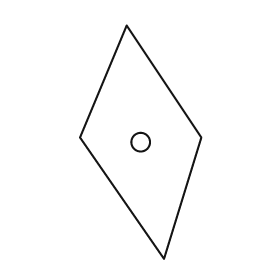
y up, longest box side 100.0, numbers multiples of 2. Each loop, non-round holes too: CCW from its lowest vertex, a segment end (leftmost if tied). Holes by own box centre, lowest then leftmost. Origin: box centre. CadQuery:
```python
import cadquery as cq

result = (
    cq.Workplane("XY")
    .moveTo(10.0, -50.0)
    .lineTo(26.0, 2.0)
    .lineTo(-6.0, 50.0)
    .lineTo(-26.0, 2.0)
    .close()
    .moveTo(0.0, 0.0)
    .circle(4.0)
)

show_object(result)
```